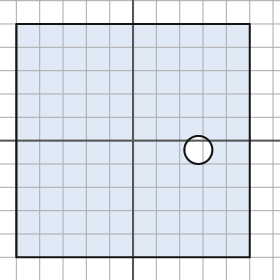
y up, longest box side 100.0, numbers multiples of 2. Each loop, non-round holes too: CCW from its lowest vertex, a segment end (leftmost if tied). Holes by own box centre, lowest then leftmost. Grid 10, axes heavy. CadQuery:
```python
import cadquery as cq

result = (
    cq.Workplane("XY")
    .moveTo(-50.0, -50.0)
    .lineTo(50.0, -50.0)
    .lineTo(50.0, 50.0)
    .lineTo(-50.0, 50.0)
    .close()
    .moveTo(28.0, -4.0)
    .circle(6.0)
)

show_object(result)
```